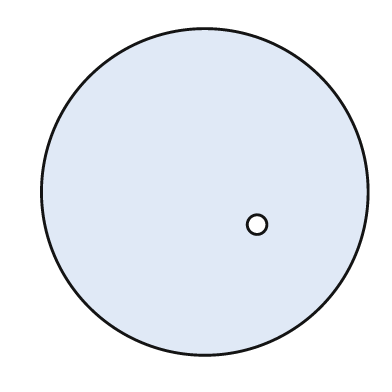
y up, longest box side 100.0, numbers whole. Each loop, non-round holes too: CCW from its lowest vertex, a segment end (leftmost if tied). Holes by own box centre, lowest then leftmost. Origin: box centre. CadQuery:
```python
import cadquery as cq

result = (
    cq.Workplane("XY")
    .moveTo(0.0, 0.0)
    .circle(50.0)
    .moveTo(16.0, -10.0)
    .circle(3.0)
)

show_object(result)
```